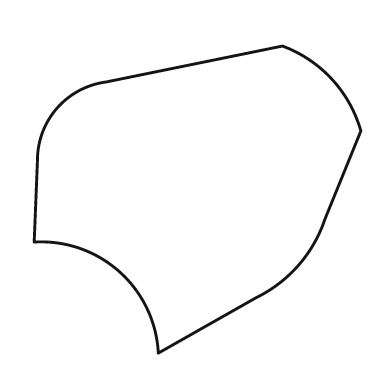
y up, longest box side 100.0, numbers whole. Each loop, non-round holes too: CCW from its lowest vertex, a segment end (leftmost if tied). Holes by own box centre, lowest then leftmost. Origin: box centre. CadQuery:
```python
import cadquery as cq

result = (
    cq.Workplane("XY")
    .moveTo(-12.0, -47.0)
    .lineTo(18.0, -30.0)
    .threePointArc((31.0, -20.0), (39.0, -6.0))
    .lineTo(50.0, 21.0)
    .threePointArc((41.0, 37.0), (26.0, 47.0))
    .lineTo(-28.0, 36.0)
    .threePointArc((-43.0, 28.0), (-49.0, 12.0))
    .lineTo(-50.0, -13.0)
    .threePointArc((-24.0, -22.0), (-12.0, -47.0))
    .close()
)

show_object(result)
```